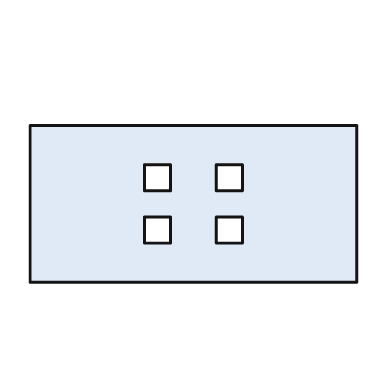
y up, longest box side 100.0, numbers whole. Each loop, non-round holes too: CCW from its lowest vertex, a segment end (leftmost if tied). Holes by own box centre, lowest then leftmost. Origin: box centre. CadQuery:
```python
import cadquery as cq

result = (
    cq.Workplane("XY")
    .moveTo(-50.0, -24.0)
    .lineTo(50.0, -24.0)
    .lineTo(50.0, 24.0)
    .lineTo(-50.0, 24.0)
    .close()
    .moveTo(-15.0, -12.0)
    .lineTo(-7.0, -12.0)
    .lineTo(-7.0, -4.0)
    .lineTo(-15.0, -4.0)
    .close()
    .moveTo(7.0, -12.0)
    .lineTo(15.0, -12.0)
    .lineTo(15.0, -4.0)
    .lineTo(7.0, -4.0)
    .close()
    .moveTo(-15.0, 4.0)
    .lineTo(-7.0, 4.0)
    .lineTo(-7.0, 12.0)
    .lineTo(-15.0, 12.0)
    .close()
    .moveTo(7.0, 4.0)
    .lineTo(15.0, 4.0)
    .lineTo(15.0, 12.0)
    .lineTo(7.0, 12.0)
    .close()
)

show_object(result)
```